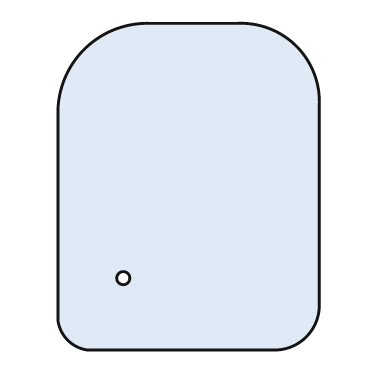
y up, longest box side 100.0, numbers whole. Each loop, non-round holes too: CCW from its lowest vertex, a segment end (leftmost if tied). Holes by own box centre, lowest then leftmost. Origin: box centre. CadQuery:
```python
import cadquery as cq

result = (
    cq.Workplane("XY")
    .moveTo(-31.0, -50.0)
    .lineTo(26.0, -50.0)
    .threePointArc((36.0, -46.0), (40.0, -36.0))
    .lineTo(40.0, 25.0)
    .threePointArc((33.0, 43.0), (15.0, 50.0))
    .lineTo(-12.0, 50.0)
    .threePointArc((-32.0, 42.0), (-40.0, 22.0))
    .lineTo(-40.0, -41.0)
    .threePointArc((-37.0, -47.0), (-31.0, -50.0))
    .close()
    .moveTo(-20.0, -28.0)
    .circle(2.0)
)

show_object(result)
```